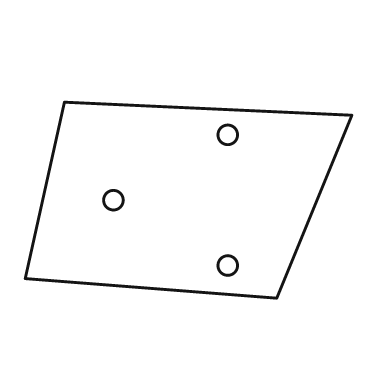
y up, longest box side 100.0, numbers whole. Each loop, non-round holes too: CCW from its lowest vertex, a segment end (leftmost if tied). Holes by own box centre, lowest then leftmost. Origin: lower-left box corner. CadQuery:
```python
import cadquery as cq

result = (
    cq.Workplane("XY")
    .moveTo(77.0, 0.0)
    .lineTo(100.0, 56.0)
    .lineTo(12.0, 60.0)
    .lineTo(0.0, 6.0)
    .close()
    .moveTo(62.0, 10.0)
    .circle(3.0)
    .moveTo(27.0, 30.0)
    .circle(3.0)
    .moveTo(62.0, 50.0)
    .circle(3.0)
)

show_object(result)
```